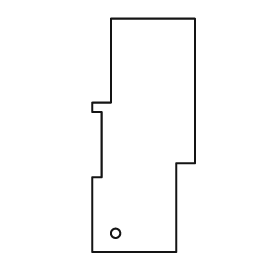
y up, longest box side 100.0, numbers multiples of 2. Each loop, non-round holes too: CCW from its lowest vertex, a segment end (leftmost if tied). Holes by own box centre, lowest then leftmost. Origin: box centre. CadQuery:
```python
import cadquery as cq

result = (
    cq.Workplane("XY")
    .moveTo(-22.0, -50.0)
    .lineTo(14.0, -50.0)
    .lineTo(14.0, -12.0)
    .lineTo(22.0, -12.0)
    .lineTo(22.0, 50.0)
    .lineTo(-14.0, 50.0)
    .lineTo(-14.0, 14.0)
    .lineTo(-22.0, 14.0)
    .lineTo(-22.0, 10.0)
    .lineTo(-18.0, 10.0)
    .lineTo(-18.0, -18.0)
    .lineTo(-22.0, -18.0)
    .close()
    .moveTo(-12.0, -42.0)
    .circle(2.0)
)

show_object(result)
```